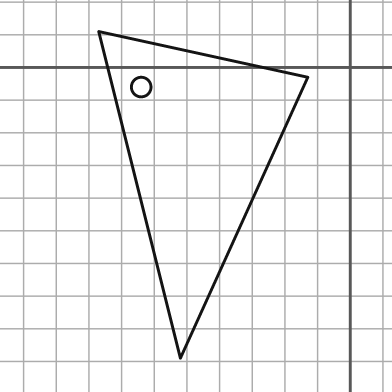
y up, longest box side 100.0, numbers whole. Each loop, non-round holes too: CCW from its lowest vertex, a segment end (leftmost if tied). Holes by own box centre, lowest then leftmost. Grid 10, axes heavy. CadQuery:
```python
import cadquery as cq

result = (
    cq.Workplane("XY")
    .moveTo(-52.0, -89.0)
    .lineTo(-13.0, -3.0)
    .lineTo(-77.0, 11.0)
    .close()
    .moveTo(-64.0, -6.0)
    .circle(3.0)
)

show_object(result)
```